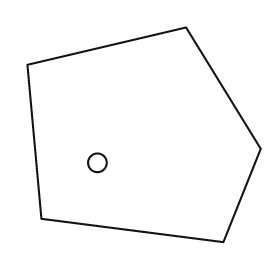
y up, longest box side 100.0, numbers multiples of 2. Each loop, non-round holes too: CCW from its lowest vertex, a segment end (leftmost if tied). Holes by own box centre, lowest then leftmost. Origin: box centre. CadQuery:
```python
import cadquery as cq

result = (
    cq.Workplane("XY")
    .moveTo(34.0, -46.0)
    .lineTo(50.0, -6.0)
    .lineTo(18.0, 46.0)
    .lineTo(-50.0, 30.0)
    .lineTo(-44.0, -36.0)
    .close()
    .moveTo(-20.0, -12.0)
    .circle(4.0)
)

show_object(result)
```